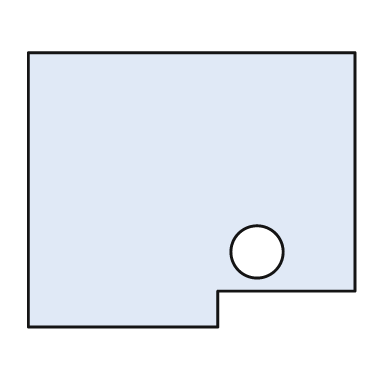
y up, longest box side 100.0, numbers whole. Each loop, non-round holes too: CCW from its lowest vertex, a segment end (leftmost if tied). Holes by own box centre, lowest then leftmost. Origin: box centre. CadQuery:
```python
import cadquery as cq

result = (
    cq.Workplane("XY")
    .moveTo(-50.0, -42.0)
    .lineTo(8.0, -42.0)
    .lineTo(8.0, -31.0)
    .lineTo(50.0, -31.0)
    .lineTo(50.0, 42.0)
    .lineTo(-50.0, 42.0)
    .close()
    .moveTo(20.0, -19.0)
    .circle(8.0)
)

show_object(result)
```